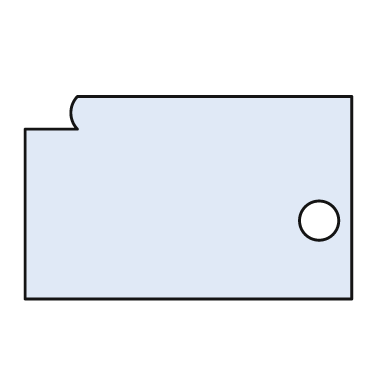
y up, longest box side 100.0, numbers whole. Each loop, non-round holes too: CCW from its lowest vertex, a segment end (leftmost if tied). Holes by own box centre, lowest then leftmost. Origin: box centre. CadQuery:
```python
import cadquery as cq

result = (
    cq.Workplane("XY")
    .moveTo(-50.0, -31.0)
    .lineTo(50.0, -31.0)
    .lineTo(50.0, 31.0)
    .lineTo(-34.0, 31.0)
    .threePointArc((-36.0, 26.0), (-34.0, 21.0))
    .lineTo(-50.0, 21.0)
    .close()
    .moveTo(40.0, -7.0)
    .circle(6.0)
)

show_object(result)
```